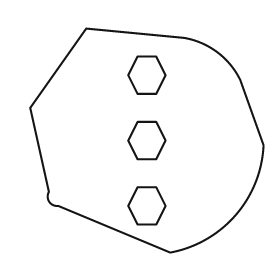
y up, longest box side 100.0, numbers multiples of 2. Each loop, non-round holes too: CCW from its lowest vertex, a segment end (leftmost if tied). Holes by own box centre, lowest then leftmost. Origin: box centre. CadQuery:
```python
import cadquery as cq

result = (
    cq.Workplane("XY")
    .moveTo(10.0, -48.0)
    .threePointArc((38.0, -32.0), (50.0, -2.0))
    .lineTo(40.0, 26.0)
    .threePointArc((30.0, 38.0), (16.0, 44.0))
    .lineTo(-26.0, 48.0)
    .lineTo(-50.0, 14.0)
    .lineTo(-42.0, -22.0)
    .threePointArc((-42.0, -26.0), (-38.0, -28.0))
    .close()
    .moveTo(-4.0, -36.0)
    .lineTo(4.0, -36.0)
    .lineTo(8.0, -28.0)
    .lineTo(4.0, -20.0)
    .lineTo(-4.0, -20.0)
    .lineTo(-8.0, -28.0)
    .close()
    .moveTo(-4.0, -8.0)
    .lineTo(4.0, -8.0)
    .lineTo(8.0, 0.0)
    .lineTo(4.0, 8.0)
    .lineTo(-4.0, 8.0)
    .lineTo(-8.0, 0.0)
    .close()
    .moveTo(-4.0, 20.0)
    .lineTo(4.0, 20.0)
    .lineTo(8.0, 28.0)
    .lineTo(4.0, 36.0)
    .lineTo(-4.0, 36.0)
    .lineTo(-8.0, 28.0)
    .close()
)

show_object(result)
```